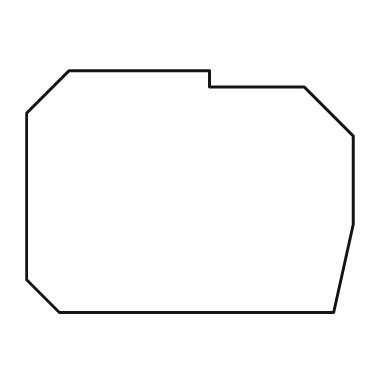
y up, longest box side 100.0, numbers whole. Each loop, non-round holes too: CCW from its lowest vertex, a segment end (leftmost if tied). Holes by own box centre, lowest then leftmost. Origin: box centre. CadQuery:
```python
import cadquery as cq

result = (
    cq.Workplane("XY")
    .moveTo(-40.0, -37.0)
    .lineTo(44.0, -37.0)
    .lineTo(50.0, -10.0)
    .lineTo(50.0, 17.0)
    .lineTo(35.0, 32.0)
    .lineTo(6.0, 32.0)
    .lineTo(6.0, 37.0)
    .lineTo(-37.0, 37.0)
    .lineTo(-50.0, 24.0)
    .lineTo(-50.0, -27.0)
    .close()
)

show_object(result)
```